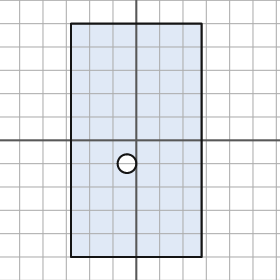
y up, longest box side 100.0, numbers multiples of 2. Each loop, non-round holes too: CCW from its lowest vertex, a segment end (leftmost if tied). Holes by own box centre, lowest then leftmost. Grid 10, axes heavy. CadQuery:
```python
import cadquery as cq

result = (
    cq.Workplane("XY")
    .moveTo(-28.0, -50.0)
    .lineTo(28.0, -50.0)
    .lineTo(28.0, 50.0)
    .lineTo(-28.0, 50.0)
    .close()
    .moveTo(-4.0, -10.0)
    .circle(4.0)
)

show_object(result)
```